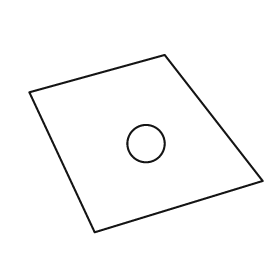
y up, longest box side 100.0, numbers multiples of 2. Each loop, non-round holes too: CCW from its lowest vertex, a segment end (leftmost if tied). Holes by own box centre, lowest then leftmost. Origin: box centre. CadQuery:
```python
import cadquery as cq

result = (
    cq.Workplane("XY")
    .moveTo(-22.0, -38.0)
    .lineTo(50.0, -16.0)
    .lineTo(8.0, 38.0)
    .lineTo(-50.0, 22.0)
    .close()
    .moveTo(0.0, 0.0)
    .circle(8.0)
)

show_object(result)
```